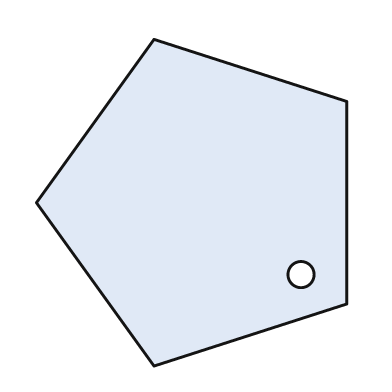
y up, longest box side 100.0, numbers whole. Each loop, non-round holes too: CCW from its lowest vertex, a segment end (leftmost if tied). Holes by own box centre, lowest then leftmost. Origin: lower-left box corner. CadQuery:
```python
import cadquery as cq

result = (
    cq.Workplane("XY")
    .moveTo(36.0, 0.0)
    .lineTo(95.0, 19.0)
    .lineTo(95.0, 81.0)
    .lineTo(36.0, 100.0)
    .lineTo(0.0, 50.0)
    .close()
    .moveTo(81.0, 28.0)
    .circle(4.0)
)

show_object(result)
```